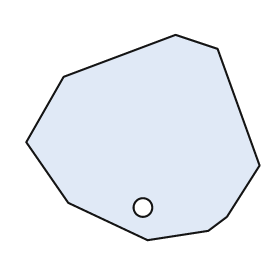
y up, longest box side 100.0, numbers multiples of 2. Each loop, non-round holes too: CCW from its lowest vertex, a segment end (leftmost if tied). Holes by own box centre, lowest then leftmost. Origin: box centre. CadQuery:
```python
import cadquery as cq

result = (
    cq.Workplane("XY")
    .moveTo(2.0, -44.0)
    .lineTo(28.0, -40.0)
    .lineTo(36.0, -34.0)
    .lineTo(50.0, -12.0)
    .lineTo(32.0, 38.0)
    .lineTo(14.0, 44.0)
    .lineTo(-34.0, 26.0)
    .lineTo(-50.0, -2.0)
    .lineTo(-32.0, -28.0)
    .close()
    .moveTo(0.0, -30.0)
    .circle(4.0)
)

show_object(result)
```